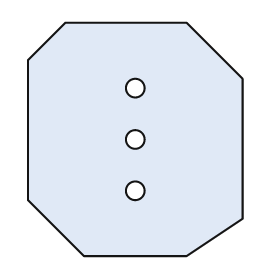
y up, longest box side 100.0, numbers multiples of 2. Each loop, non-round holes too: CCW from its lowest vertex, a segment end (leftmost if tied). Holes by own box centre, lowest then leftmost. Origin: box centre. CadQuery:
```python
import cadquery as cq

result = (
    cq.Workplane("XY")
    .moveTo(-22.0, -50.0)
    .lineTo(22.0, -50.0)
    .lineTo(46.0, -34.0)
    .lineTo(46.0, 26.0)
    .lineTo(22.0, 50.0)
    .lineTo(-30.0, 50.0)
    .lineTo(-46.0, 34.0)
    .lineTo(-46.0, -26.0)
    .close()
    .moveTo(0.0, -22.0)
    .circle(4.0)
    .moveTo(0.0, 0.0)
    .circle(4.0)
    .moveTo(0.0, 22.0)
    .circle(4.0)
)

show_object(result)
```